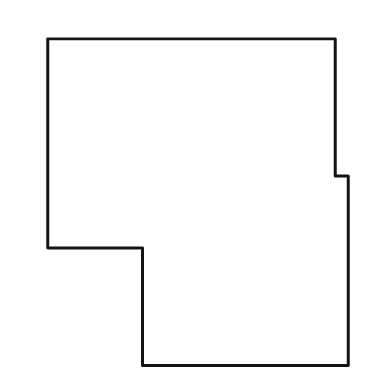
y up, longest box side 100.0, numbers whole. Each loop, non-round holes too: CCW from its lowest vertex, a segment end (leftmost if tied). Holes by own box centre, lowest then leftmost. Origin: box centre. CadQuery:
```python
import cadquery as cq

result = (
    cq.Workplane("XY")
    .moveTo(-17.0, -50.0)
    .lineTo(46.0, -50.0)
    .lineTo(46.0, 8.0)
    .lineTo(42.0, 8.0)
    .lineTo(42.0, 50.0)
    .lineTo(-46.0, 50.0)
    .lineTo(-46.0, -14.0)
    .lineTo(-17.0, -14.0)
    .close()
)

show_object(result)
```